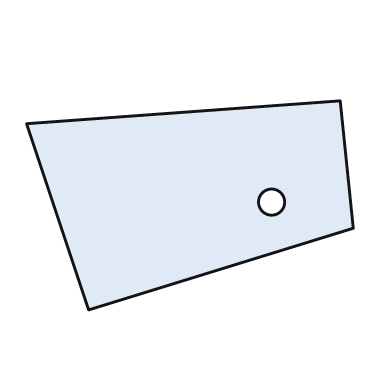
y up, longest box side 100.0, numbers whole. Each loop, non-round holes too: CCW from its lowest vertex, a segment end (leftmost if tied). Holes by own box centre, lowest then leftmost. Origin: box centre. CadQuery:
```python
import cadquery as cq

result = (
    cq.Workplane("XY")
    .moveTo(-31.0, -32.0)
    .lineTo(50.0, -7.0)
    .lineTo(46.0, 32.0)
    .lineTo(-50.0, 25.0)
    .close()
    .moveTo(25.0, 1.0)
    .circle(4.0)
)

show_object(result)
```